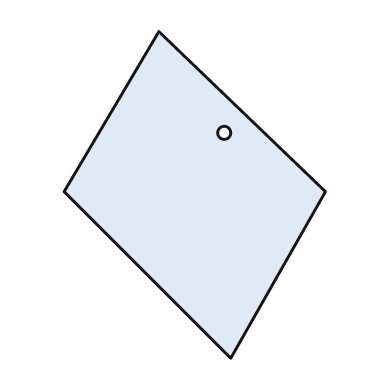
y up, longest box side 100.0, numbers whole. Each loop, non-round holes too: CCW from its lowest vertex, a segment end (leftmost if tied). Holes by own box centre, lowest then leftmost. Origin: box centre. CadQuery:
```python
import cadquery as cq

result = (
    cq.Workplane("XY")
    .moveTo(11.0, -50.0)
    .lineTo(40.0, 1.0)
    .lineTo(-11.0, 50.0)
    .lineTo(-40.0, 1.0)
    .close()
    .moveTo(9.0, 19.0)
    .circle(2.0)
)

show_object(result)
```